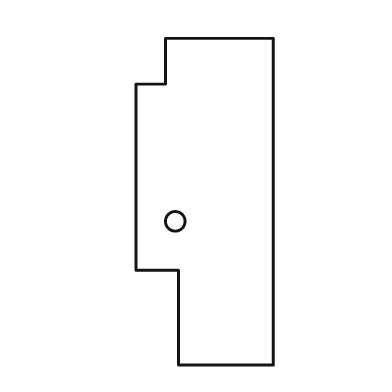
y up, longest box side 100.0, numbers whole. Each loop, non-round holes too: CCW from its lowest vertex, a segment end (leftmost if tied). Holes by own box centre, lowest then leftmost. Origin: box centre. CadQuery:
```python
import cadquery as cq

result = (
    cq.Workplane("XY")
    .moveTo(-8.0, -50.0)
    .lineTo(21.0, -50.0)
    .lineTo(21.0, 50.0)
    .lineTo(-12.0, 50.0)
    .lineTo(-12.0, 36.0)
    .lineTo(-21.0, 36.0)
    .lineTo(-21.0, -21.0)
    .lineTo(-8.0, -21.0)
    .close()
    .moveTo(-9.0, -6.0)
    .circle(3.0)
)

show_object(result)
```